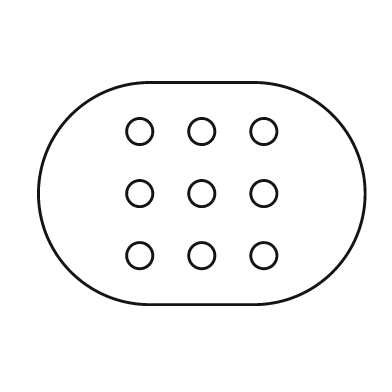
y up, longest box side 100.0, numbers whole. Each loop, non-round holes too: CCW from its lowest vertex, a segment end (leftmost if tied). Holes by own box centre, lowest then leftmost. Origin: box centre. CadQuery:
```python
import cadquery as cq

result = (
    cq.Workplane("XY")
    .moveTo(-16.0, -34.0)
    .lineTo(16.0, -34.0)
    .threePointArc((50.0, 0.0), (16.0, 34.0))
    .lineTo(-16.0, 34.0)
    .threePointArc((-50.0, 0.0), (-16.0, -34.0))
    .close()
    .moveTo(-19.0, -19.0)
    .circle(4.0)
    .moveTo(0.0, -19.0)
    .circle(4.0)
    .moveTo(19.0, -19.0)
    .circle(4.0)
    .moveTo(-19.0, 0.0)
    .circle(4.0)
    .moveTo(0.0, 0.0)
    .circle(4.0)
    .moveTo(19.0, 0.0)
    .circle(4.0)
    .moveTo(-19.0, 19.0)
    .circle(4.0)
    .moveTo(0.0, 19.0)
    .circle(4.0)
    .moveTo(19.0, 19.0)
    .circle(4.0)
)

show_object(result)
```